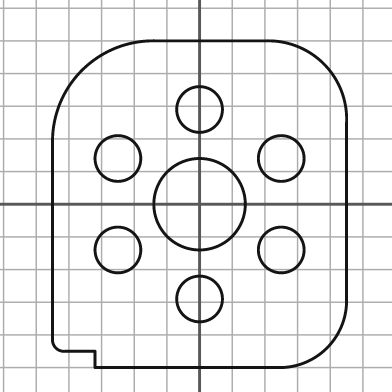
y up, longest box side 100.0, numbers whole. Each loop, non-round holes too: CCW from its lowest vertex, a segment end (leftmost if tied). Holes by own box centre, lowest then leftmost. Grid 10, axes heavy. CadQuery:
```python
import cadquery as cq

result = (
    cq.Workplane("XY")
    .moveTo(-32.0, -50.0)
    .lineTo(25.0, -50.0)
    .threePointArc((39.0, -44.0), (45.0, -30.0))
    .lineTo(45.0, 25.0)
    .threePointArc((38.0, 43.0), (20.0, 50.0))
    .lineTo(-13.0, 50.0)
    .threePointArc((-36.0, 41.0), (-45.0, 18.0))
    .lineTo(-45.0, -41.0)
    .threePointArc((-44.0, -44.0), (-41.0, -45.0))
    .lineTo(-32.0, -45.0)
    .close()
    .moveTo(0.0, -29.0)
    .circle(7.0)
    .moveTo(-25.0, -14.0)
    .circle(7.0)
    .moveTo(25.0, -14.0)
    .circle(7.0)
    .moveTo(0.0, 0.0)
    .circle(14.0)
    .moveTo(-25.0, 14.0)
    .circle(7.0)
    .moveTo(25.0, 14.0)
    .circle(7.0)
    .moveTo(0.0, 29.0)
    .circle(7.0)
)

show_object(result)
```